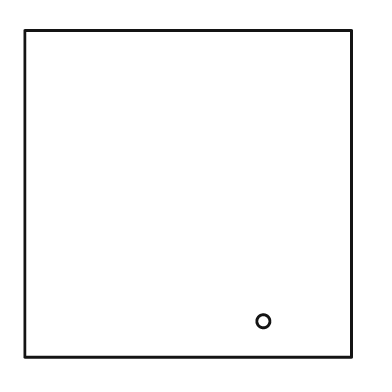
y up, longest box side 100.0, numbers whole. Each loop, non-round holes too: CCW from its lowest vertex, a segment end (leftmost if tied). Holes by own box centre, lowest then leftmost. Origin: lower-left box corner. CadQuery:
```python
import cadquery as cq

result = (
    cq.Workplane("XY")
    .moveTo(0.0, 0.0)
    .lineTo(100.0, 0.0)
    .lineTo(100.0, 100.0)
    .lineTo(0.0, 100.0)
    .close()
    .moveTo(73.0, 11.0)
    .circle(2.0)
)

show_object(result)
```